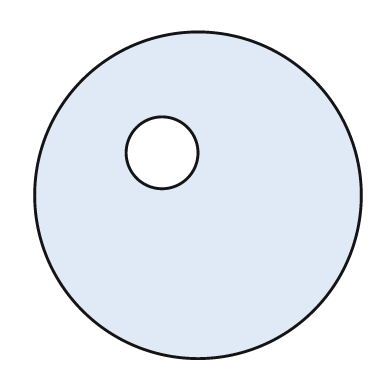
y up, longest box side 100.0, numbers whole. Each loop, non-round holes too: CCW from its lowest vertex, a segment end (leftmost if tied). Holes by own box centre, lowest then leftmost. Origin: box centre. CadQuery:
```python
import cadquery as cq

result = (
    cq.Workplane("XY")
    .moveTo(0.0, 0.0)
    .circle(50.0)
    .moveTo(-11.0, 13.0)
    .circle(11.0)
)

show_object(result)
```